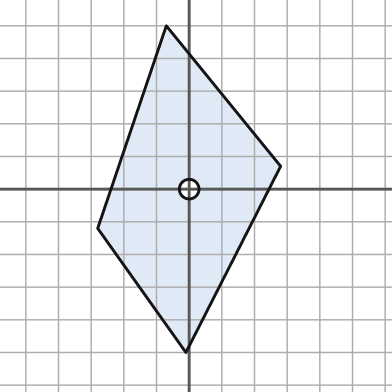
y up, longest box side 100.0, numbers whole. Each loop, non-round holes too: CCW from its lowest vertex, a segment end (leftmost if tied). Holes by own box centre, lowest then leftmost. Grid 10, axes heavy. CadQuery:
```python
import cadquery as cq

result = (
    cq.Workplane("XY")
    .moveTo(-1.0, -50.0)
    .lineTo(28.0, 7.0)
    .lineTo(-7.0, 50.0)
    .lineTo(-28.0, -12.0)
    .close()
    .moveTo(0.0, 0.0)
    .circle(3.0)
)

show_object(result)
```